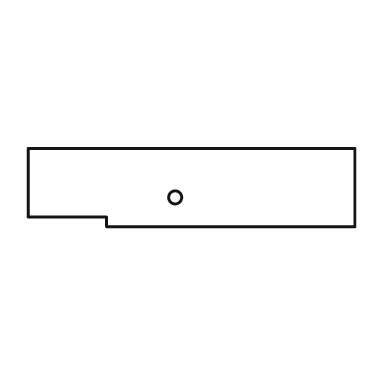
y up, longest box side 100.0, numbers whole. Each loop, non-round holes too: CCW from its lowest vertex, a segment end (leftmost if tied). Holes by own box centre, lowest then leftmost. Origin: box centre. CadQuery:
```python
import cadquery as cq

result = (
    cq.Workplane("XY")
    .moveTo(-26.0, -12.0)
    .lineTo(50.0, -12.0)
    .lineTo(50.0, 12.0)
    .lineTo(-50.0, 12.0)
    .lineTo(-50.0, -9.0)
    .lineTo(-26.0, -9.0)
    .close()
    .moveTo(-5.0, -3.0)
    .circle(2.0)
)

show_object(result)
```